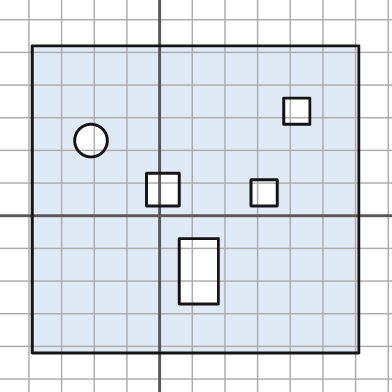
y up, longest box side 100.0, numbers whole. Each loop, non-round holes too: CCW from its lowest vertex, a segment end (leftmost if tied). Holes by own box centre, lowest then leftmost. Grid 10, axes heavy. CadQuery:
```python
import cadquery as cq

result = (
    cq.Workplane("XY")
    .moveTo(-39.0, -42.0)
    .lineTo(61.0, -42.0)
    .lineTo(61.0, 52.0)
    .lineTo(-39.0, 52.0)
    .close()
    .moveTo(6.0, -27.0)
    .lineTo(18.0, -27.0)
    .lineTo(18.0, -7.0)
    .lineTo(6.0, -7.0)
    .close()
    .moveTo(28.0, 3.0)
    .lineTo(36.0, 3.0)
    .lineTo(36.0, 11.0)
    .lineTo(28.0, 11.0)
    .close()
    .moveTo(-4.0, 3.0)
    .lineTo(6.0, 3.0)
    .lineTo(6.0, 13.0)
    .lineTo(-4.0, 13.0)
    .close()
    .moveTo(-21.0, 23.0)
    .circle(5.0)
    .moveTo(38.0, 28.0)
    .lineTo(46.0, 28.0)
    .lineTo(46.0, 36.0)
    .lineTo(38.0, 36.0)
    .close()
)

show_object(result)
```